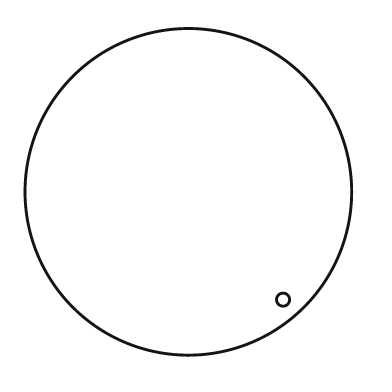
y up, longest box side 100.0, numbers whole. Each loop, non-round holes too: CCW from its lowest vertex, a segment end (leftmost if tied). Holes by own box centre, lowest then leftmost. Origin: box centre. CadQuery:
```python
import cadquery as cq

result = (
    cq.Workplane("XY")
    .moveTo(0.0, 0.0)
    .circle(50.0)
    .moveTo(29.0, -33.0)
    .circle(2.0)
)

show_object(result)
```